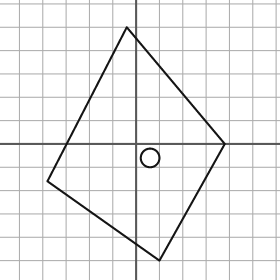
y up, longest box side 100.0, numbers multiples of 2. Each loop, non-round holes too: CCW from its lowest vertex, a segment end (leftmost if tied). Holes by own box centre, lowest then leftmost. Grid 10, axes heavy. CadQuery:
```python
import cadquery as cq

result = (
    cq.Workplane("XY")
    .moveTo(10.0, -50.0)
    .lineTo(38.0, 0.0)
    .lineTo(-4.0, 50.0)
    .lineTo(-38.0, -16.0)
    .close()
    .moveTo(6.0, -6.0)
    .circle(4.0)
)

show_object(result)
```